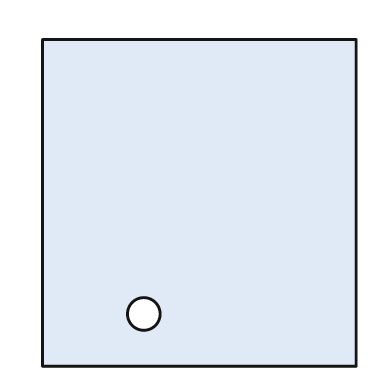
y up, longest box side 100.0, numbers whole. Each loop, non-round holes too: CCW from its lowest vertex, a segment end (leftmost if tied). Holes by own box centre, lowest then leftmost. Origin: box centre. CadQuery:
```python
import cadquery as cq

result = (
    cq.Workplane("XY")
    .moveTo(-48.0, -50.0)
    .lineTo(48.0, -50.0)
    .lineTo(48.0, 50.0)
    .lineTo(-48.0, 50.0)
    .close()
    .moveTo(-17.0, -34.0)
    .circle(5.0)
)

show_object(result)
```